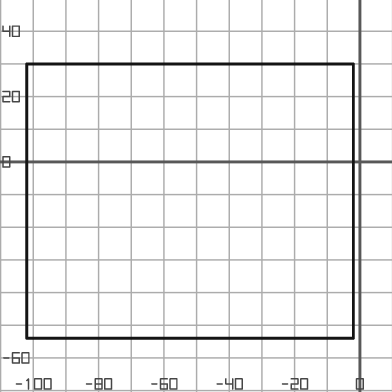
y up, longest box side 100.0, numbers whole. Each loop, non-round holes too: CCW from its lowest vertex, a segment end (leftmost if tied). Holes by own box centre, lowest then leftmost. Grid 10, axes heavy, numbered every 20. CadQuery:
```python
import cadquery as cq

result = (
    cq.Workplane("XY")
    .moveTo(-102.0, -54.0)
    .lineTo(-2.0, -54.0)
    .lineTo(-2.0, 30.0)
    .lineTo(-102.0, 30.0)
    .close()
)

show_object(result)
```